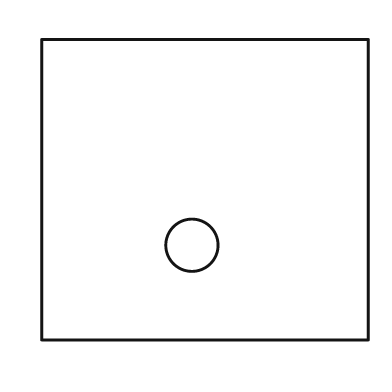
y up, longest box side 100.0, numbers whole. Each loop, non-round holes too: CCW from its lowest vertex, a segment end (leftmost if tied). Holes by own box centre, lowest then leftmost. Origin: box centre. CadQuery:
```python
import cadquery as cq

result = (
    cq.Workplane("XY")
    .moveTo(-50.0, -46.0)
    .lineTo(50.0, -46.0)
    .lineTo(50.0, 46.0)
    .lineTo(-50.0, 46.0)
    .close()
    .moveTo(-4.0, -17.0)
    .circle(8.0)
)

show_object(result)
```